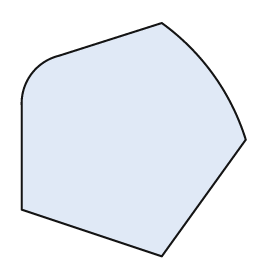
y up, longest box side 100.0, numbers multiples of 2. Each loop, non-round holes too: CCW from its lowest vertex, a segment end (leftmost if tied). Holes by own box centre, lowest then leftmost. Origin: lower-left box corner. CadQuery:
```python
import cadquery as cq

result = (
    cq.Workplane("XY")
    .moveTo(60.0, 0.0)
    .lineTo(96.0, 50.0)
    .threePointArc((82.0, 78.0), (60.0, 100.0))
    .lineTo(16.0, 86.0)
    .threePointArc((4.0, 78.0), (0.0, 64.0))
    .lineTo(0.0, 20.0)
    .close()
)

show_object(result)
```